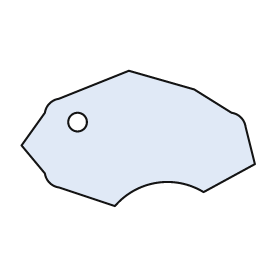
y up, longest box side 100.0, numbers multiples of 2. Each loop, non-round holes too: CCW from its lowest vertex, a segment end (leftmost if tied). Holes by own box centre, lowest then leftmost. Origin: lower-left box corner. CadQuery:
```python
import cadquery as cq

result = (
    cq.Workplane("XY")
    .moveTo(40.0, 0.0)
    .threePointArc((58.0, 10.0), (78.0, 6.0))
    .lineTo(100.0, 18.0)
    .lineTo(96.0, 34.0)
    .threePointArc((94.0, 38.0), (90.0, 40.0))
    .lineTo(74.0, 50.0)
    .lineTo(46.0, 58.0)
    .lineTo(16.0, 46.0)
    .threePointArc((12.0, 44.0), (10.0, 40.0))
    .lineTo(0.0, 26.0)
    .lineTo(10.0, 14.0)
    .threePointArc((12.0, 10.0), (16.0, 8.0))
    .close()
    .moveTo(24.0, 36.0)
    .circle(4.0)
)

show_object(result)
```